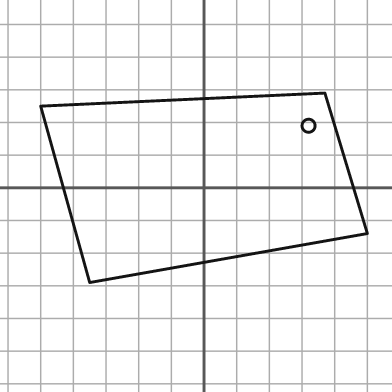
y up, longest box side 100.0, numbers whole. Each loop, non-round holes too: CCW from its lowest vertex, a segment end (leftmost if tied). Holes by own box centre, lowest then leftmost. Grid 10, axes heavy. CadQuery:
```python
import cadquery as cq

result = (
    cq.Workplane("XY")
    .moveTo(-35.0, -29.0)
    .lineTo(50.0, -14.0)
    .lineTo(37.0, 29.0)
    .lineTo(-50.0, 25.0)
    .close()
    .moveTo(32.0, 19.0)
    .circle(2.0)
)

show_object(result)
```